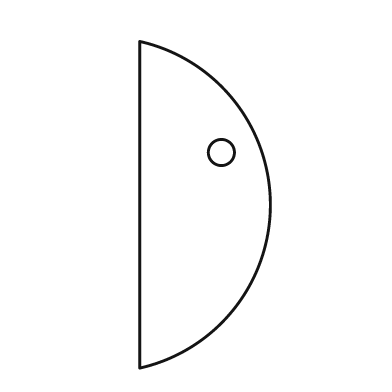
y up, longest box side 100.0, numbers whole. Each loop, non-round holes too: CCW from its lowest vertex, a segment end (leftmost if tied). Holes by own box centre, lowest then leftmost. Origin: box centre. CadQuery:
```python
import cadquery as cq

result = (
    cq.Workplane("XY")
    .moveTo(-20.0, -50.0)
    .threePointArc((20.0, 0.0), (-20.0, 50.0))
    .close()
    .moveTo(5.0, 16.0)
    .circle(4.0)
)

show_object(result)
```